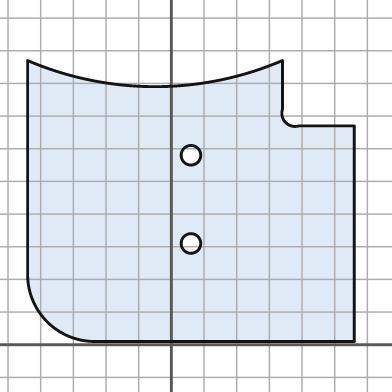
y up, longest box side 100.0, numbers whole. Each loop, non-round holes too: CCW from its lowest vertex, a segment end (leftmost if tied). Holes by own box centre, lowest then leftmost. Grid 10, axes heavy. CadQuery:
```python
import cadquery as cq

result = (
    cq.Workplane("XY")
    .moveTo(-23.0, 1.0)
    .lineTo(56.0, 1.0)
    .lineTo(56.0, 67.0)
    .lineTo(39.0, 67.0)
    .threePointArc((35.0, 68.0), (34.0, 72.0))
    .lineTo(34.0, 87.0)
    .threePointArc((-5.0, 79.0), (-44.0, 87.0))
    .lineTo(-44.0, 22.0)
    .threePointArc((-38.0, 7.0), (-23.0, 1.0))
    .close()
    .moveTo(6.0, 31.0)
    .circle(3.0)
    .moveTo(6.0, 58.0)
    .circle(3.0)
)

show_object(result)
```